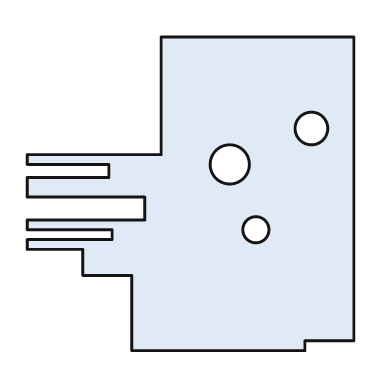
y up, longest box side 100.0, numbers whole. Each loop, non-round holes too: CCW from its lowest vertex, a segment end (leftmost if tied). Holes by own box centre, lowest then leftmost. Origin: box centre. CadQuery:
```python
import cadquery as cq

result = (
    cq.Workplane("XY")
    .moveTo(-18.0, -48.0)
    .lineTo(35.0, -48.0)
    .lineTo(35.0, -45.0)
    .lineTo(50.0, -45.0)
    .lineTo(50.0, 48.0)
    .lineTo(-9.0, 48.0)
    .lineTo(-9.0, 12.0)
    .lineTo(-50.0, 12.0)
    .lineTo(-50.0, 9.0)
    .lineTo(-25.0, 9.0)
    .lineTo(-25.0, 5.0)
    .lineTo(-50.0, 5.0)
    .lineTo(-50.0, -1.0)
    .lineTo(-14.0, -1.0)
    .lineTo(-14.0, -8.0)
    .lineTo(-50.0, -8.0)
    .lineTo(-50.0, -11.0)
    .lineTo(-24.0, -11.0)
    .lineTo(-24.0, -14.0)
    .lineTo(-50.0, -14.0)
    .lineTo(-50.0, -17.0)
    .lineTo(-33.0, -17.0)
    .lineTo(-33.0, -25.0)
    .lineTo(-18.0, -25.0)
    .close()
    .moveTo(20.0, -11.0)
    .circle(4.0)
    .moveTo(12.0, 9.0)
    .circle(6.0)
    .moveTo(37.0, 20.0)
    .circle(5.0)
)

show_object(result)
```